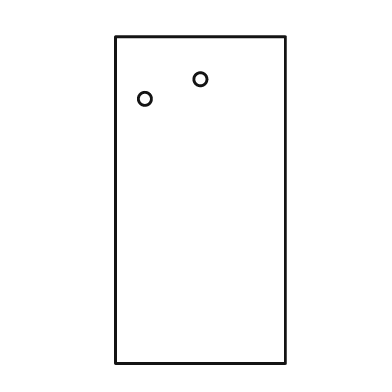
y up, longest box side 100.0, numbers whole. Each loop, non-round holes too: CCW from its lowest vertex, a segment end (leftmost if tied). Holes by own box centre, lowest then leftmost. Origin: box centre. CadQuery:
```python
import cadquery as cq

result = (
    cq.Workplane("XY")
    .moveTo(-26.0, -50.0)
    .lineTo(26.0, -50.0)
    .lineTo(26.0, 50.0)
    .lineTo(-26.0, 50.0)
    .close()
    .moveTo(-17.0, 31.0)
    .circle(2.0)
    .moveTo(0.0, 37.0)
    .circle(2.0)
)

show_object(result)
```